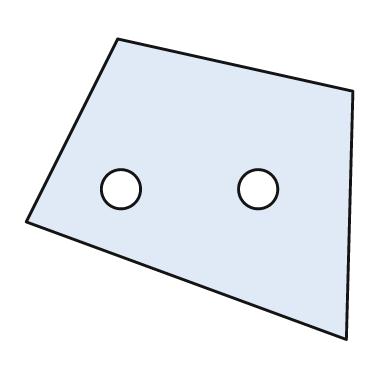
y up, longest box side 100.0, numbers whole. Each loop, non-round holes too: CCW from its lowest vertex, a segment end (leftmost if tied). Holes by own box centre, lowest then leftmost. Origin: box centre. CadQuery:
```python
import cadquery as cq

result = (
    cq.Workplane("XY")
    .moveTo(48.0, -46.0)
    .lineTo(50.0, 30.0)
    .lineTo(-22.0, 46.0)
    .lineTo(-50.0, -10.0)
    .close()
    .moveTo(-21.0, 0.0)
    .circle(6.0)
    .moveTo(21.0, 0.0)
    .circle(6.0)
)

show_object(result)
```